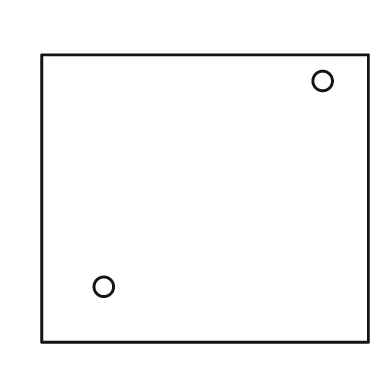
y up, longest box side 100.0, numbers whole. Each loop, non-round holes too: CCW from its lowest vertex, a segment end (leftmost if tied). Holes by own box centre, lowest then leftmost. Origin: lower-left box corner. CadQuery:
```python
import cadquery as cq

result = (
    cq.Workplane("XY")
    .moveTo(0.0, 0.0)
    .lineTo(100.0, 0.0)
    .lineTo(100.0, 88.0)
    .lineTo(0.0, 88.0)
    .close()
    .moveTo(19.0, 17.0)
    .circle(3.0)
    .moveTo(86.0, 80.0)
    .circle(3.0)
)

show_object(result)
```